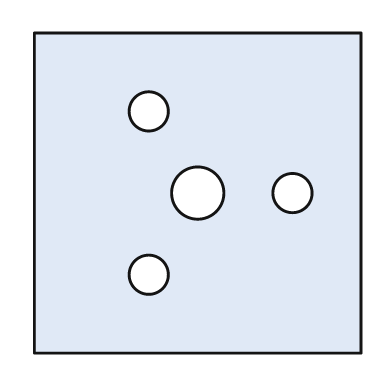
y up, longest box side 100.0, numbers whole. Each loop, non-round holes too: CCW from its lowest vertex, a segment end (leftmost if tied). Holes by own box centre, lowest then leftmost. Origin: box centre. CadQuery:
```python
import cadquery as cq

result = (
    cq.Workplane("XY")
    .moveTo(-50.0, -49.0)
    .lineTo(50.0, -49.0)
    .lineTo(50.0, 49.0)
    .lineTo(-50.0, 49.0)
    .close()
    .moveTo(-15.0, -25.0)
    .circle(6.0)
    .moveTo(0.0, 0.0)
    .circle(8.0)
    .moveTo(29.0, 0.0)
    .circle(6.0)
    .moveTo(-15.0, 25.0)
    .circle(6.0)
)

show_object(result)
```